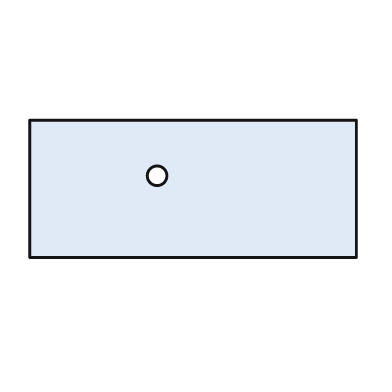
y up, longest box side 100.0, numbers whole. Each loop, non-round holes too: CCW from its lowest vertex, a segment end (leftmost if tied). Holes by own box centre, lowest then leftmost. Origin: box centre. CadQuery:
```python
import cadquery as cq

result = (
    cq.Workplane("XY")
    .moveTo(-50.0, -21.0)
    .lineTo(50.0, -21.0)
    .lineTo(50.0, 21.0)
    .lineTo(-50.0, 21.0)
    .close()
    .moveTo(-11.0, 4.0)
    .circle(3.0)
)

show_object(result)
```